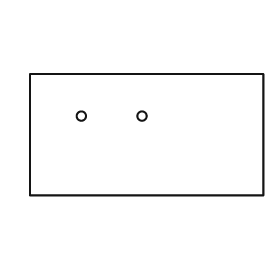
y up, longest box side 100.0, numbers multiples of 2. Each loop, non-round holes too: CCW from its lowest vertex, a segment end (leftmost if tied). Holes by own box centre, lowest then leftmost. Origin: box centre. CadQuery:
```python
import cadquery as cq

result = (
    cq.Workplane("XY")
    .moveTo(-50.0, -26.0)
    .lineTo(50.0, -26.0)
    .lineTo(50.0, 26.0)
    .lineTo(-50.0, 26.0)
    .close()
    .moveTo(-28.0, 8.0)
    .circle(2.0)
    .moveTo(-2.0, 8.0)
    .circle(2.0)
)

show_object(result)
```